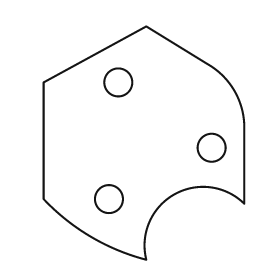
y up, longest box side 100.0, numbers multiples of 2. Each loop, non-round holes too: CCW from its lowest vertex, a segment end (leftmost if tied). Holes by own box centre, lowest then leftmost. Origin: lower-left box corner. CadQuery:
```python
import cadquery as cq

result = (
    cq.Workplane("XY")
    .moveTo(44.0, 0.0)
    .threePointArc((56.0, 28.0), (86.0, 24.0))
    .lineTo(86.0, 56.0)
    .threePointArc((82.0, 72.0), (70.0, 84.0))
    .lineTo(44.0, 100.0)
    .lineTo(0.0, 76.0)
    .lineTo(0.0, 26.0)
    .threePointArc((20.0, 10.0), (44.0, 0.0))
    .close()
    .moveTo(28.0, 26.0)
    .circle(6.0)
    .moveTo(72.0, 48.0)
    .circle(6.0)
    .moveTo(32.0, 76.0)
    .circle(6.0)
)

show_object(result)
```